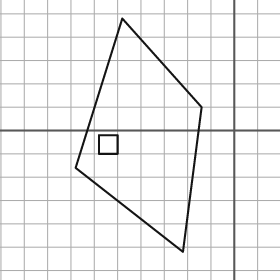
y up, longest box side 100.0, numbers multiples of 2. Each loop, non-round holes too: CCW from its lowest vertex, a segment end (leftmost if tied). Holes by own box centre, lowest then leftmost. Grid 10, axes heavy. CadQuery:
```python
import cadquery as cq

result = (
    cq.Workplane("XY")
    .moveTo(-22.0, -52.0)
    .lineTo(-14.0, 10.0)
    .lineTo(-48.0, 48.0)
    .lineTo(-68.0, -16.0)
    .close()
    .moveTo(-58.0, -10.0)
    .lineTo(-50.0, -10.0)
    .lineTo(-50.0, -2.0)
    .lineTo(-58.0, -2.0)
    .close()
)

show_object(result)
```